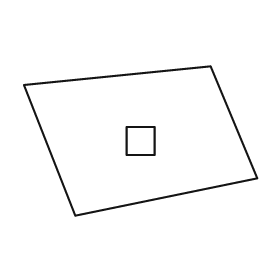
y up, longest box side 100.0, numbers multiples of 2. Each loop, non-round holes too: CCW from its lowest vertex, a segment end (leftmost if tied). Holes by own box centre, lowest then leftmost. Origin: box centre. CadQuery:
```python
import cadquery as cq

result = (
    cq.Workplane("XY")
    .moveTo(-28.0, -32.0)
    .lineTo(50.0, -16.0)
    .lineTo(30.0, 32.0)
    .lineTo(-50.0, 24.0)
    .close()
    .moveTo(-6.0, -6.0)
    .lineTo(6.0, -6.0)
    .lineTo(6.0, 6.0)
    .lineTo(-6.0, 6.0)
    .close()
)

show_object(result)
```